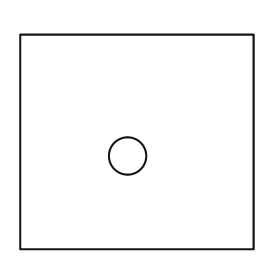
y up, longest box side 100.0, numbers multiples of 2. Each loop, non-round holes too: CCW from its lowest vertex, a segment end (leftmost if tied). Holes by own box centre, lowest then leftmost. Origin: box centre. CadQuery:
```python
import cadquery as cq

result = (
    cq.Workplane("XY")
    .moveTo(-50.0, -46.0)
    .lineTo(50.0, -46.0)
    .lineTo(50.0, 46.0)
    .lineTo(-50.0, 46.0)
    .close()
    .moveTo(-4.0, -6.0)
    .circle(8.0)
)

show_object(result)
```